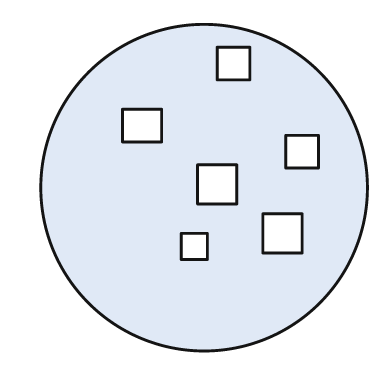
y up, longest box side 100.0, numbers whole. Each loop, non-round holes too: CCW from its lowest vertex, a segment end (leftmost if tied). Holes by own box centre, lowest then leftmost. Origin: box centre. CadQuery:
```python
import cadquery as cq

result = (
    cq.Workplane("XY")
    .moveTo(0.0, 0.0)
    .circle(50.0)
    .moveTo(-7.0, -22.0)
    .lineTo(1.0, -22.0)
    .lineTo(1.0, -14.0)
    .lineTo(-7.0, -14.0)
    .close()
    .moveTo(18.0, -20.0)
    .lineTo(30.0, -20.0)
    .lineTo(30.0, -8.0)
    .lineTo(18.0, -8.0)
    .close()
    .moveTo(-2.0, -5.0)
    .lineTo(10.0, -5.0)
    .lineTo(10.0, 7.0)
    .lineTo(-2.0, 7.0)
    .close()
    .moveTo(25.0, 6.0)
    .lineTo(35.0, 6.0)
    .lineTo(35.0, 16.0)
    .lineTo(25.0, 16.0)
    .close()
    .moveTo(-25.0, 14.0)
    .lineTo(-13.0, 14.0)
    .lineTo(-13.0, 24.0)
    .lineTo(-25.0, 24.0)
    .close()
    .moveTo(4.0, 33.0)
    .lineTo(14.0, 33.0)
    .lineTo(14.0, 43.0)
    .lineTo(4.0, 43.0)
    .close()
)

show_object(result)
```